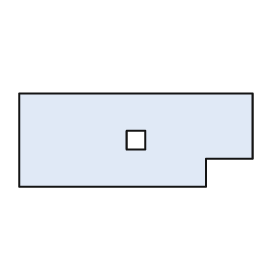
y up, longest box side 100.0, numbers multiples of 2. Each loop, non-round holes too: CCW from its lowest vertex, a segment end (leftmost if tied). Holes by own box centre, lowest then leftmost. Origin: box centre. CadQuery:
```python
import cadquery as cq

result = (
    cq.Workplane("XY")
    .moveTo(-50.0, -20.0)
    .lineTo(30.0, -20.0)
    .lineTo(30.0, -8.0)
    .lineTo(50.0, -8.0)
    .lineTo(50.0, 20.0)
    .lineTo(-50.0, 20.0)
    .close()
    .moveTo(-4.0, -4.0)
    .lineTo(4.0, -4.0)
    .lineTo(4.0, 4.0)
    .lineTo(-4.0, 4.0)
    .close()
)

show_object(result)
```